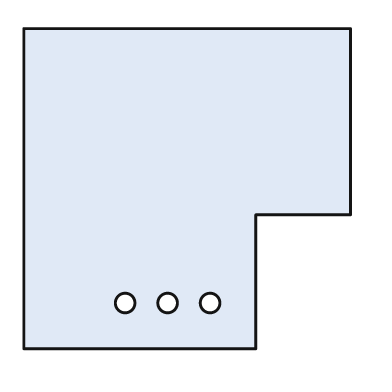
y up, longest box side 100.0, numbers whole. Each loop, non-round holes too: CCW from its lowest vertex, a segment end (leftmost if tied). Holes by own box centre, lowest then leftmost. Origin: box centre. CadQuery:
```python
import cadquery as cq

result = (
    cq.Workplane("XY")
    .moveTo(-50.0, -49.0)
    .lineTo(21.0, -49.0)
    .lineTo(21.0, -8.0)
    .lineTo(50.0, -8.0)
    .lineTo(50.0, 49.0)
    .lineTo(-50.0, 49.0)
    .close()
    .moveTo(-19.0, -35.0)
    .circle(3.0)
    .moveTo(-6.0, -35.0)
    .circle(3.0)
    .moveTo(7.0, -35.0)
    .circle(3.0)
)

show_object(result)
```